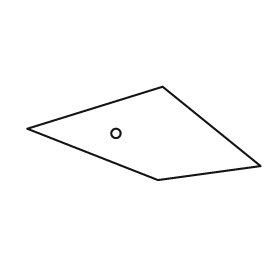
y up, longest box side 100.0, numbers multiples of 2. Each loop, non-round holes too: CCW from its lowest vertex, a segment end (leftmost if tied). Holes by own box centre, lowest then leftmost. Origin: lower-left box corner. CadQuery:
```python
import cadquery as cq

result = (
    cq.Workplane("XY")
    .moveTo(56.0, 0.0)
    .lineTo(100.0, 6.0)
    .lineTo(58.0, 40.0)
    .lineTo(0.0, 22.0)
    .close()
    .moveTo(38.0, 20.0)
    .circle(2.0)
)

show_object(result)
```